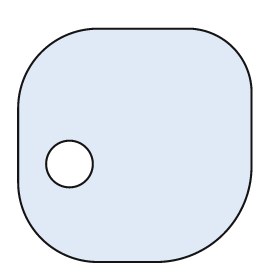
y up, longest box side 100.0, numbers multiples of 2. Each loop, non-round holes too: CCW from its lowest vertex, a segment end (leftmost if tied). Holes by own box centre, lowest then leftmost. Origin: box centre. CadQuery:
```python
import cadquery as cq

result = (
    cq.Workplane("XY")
    .moveTo(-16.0, -50.0)
    .lineTo(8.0, -50.0)
    .threePointArc((38.0, -38.0), (50.0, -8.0))
    .lineTo(50.0, 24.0)
    .threePointArc((42.0, 42.0), (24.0, 50.0))
    .lineTo(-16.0, 50.0)
    .threePointArc((-40.0, 40.0), (-50.0, 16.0))
    .lineTo(-50.0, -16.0)
    .threePointArc((-40.0, -40.0), (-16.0, -50.0))
    .close()
    .moveTo(-28.0, -8.0)
    .circle(10.0)
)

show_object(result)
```